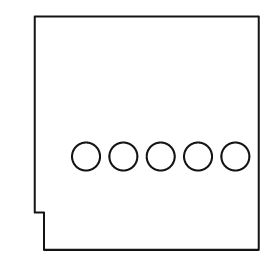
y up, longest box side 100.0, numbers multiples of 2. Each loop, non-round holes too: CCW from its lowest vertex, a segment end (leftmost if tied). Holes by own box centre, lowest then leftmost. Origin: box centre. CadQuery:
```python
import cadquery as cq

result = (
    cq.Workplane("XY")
    .moveTo(-44.0, -50.0)
    .lineTo(48.0, -50.0)
    .lineTo(48.0, 50.0)
    .lineTo(-48.0, 50.0)
    .lineTo(-48.0, -34.0)
    .lineTo(-44.0, -34.0)
    .close()
    .moveTo(-26.0, -10.0)
    .circle(6.0)
    .moveTo(-10.0, -10.0)
    .circle(6.0)
    .moveTo(6.0, -10.0)
    .circle(6.0)
    .moveTo(22.0, -10.0)
    .circle(6.0)
    .moveTo(38.0, -10.0)
    .circle(6.0)
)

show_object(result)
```